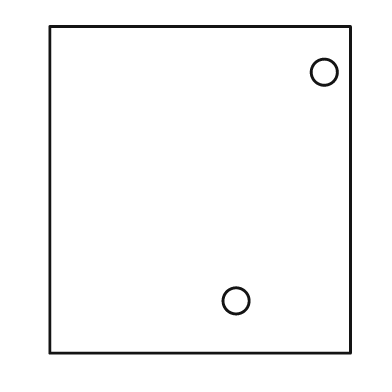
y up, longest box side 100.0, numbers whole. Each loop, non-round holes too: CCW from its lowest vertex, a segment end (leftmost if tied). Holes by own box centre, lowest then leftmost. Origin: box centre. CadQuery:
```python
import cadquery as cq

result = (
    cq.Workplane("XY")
    .moveTo(-46.0, -50.0)
    .lineTo(46.0, -50.0)
    .lineTo(46.0, 50.0)
    .lineTo(-46.0, 50.0)
    .close()
    .moveTo(11.0, -34.0)
    .circle(4.0)
    .moveTo(38.0, 36.0)
    .circle(4.0)
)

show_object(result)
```